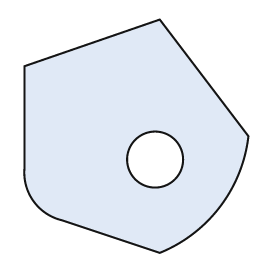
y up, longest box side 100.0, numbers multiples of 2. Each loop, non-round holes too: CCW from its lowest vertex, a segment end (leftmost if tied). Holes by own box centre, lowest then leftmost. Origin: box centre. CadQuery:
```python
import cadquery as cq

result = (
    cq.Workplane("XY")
    .moveTo(10.0, -50.0)
    .threePointArc((36.0, -30.0), (48.0, 0.0))
    .lineTo(10.0, 50.0)
    .lineTo(-48.0, 30.0)
    .lineTo(-48.0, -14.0)
    .threePointArc((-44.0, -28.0), (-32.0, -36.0))
    .close()
    .moveTo(8.0, -10.0)
    .circle(12.0)
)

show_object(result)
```